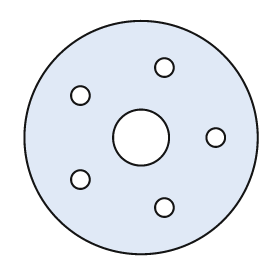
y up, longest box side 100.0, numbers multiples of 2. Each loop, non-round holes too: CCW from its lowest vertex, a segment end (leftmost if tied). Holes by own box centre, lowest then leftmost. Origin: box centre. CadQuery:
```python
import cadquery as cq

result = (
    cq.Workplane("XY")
    .moveTo(0.0, 0.0)
    .circle(50.0)
    .moveTo(10.0, -30.0)
    .circle(4.0)
    .moveTo(-26.0, -18.0)
    .circle(4.0)
    .moveTo(0.0, 0.0)
    .circle(12.0)
    .moveTo(32.0, 0.0)
    .circle(4.0)
    .moveTo(-26.0, 18.0)
    .circle(4.0)
    .moveTo(10.0, 30.0)
    .circle(4.0)
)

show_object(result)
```